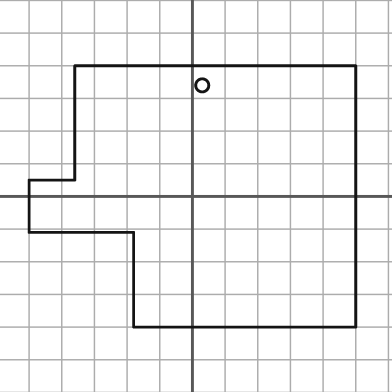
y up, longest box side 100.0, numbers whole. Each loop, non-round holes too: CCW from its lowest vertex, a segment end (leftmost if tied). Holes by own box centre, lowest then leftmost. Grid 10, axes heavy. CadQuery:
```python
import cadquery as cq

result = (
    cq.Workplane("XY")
    .moveTo(-18.0, -40.0)
    .lineTo(50.0, -40.0)
    .lineTo(50.0, 40.0)
    .lineTo(-36.0, 40.0)
    .lineTo(-36.0, 5.0)
    .lineTo(-50.0, 5.0)
    .lineTo(-50.0, -11.0)
    .lineTo(-18.0, -11.0)
    .close()
    .moveTo(3.0, 34.0)
    .circle(2.0)
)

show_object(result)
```